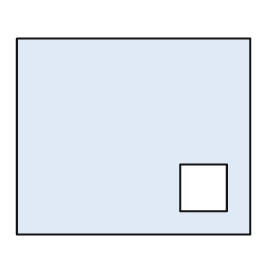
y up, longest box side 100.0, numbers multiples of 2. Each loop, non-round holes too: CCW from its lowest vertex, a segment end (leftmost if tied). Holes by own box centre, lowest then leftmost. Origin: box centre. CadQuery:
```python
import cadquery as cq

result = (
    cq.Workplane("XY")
    .moveTo(-50.0, -42.0)
    .lineTo(50.0, -42.0)
    .lineTo(50.0, 42.0)
    .lineTo(-50.0, 42.0)
    .close()
    .moveTo(20.0, -32.0)
    .lineTo(40.0, -32.0)
    .lineTo(40.0, -12.0)
    .lineTo(20.0, -12.0)
    .close()
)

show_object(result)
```